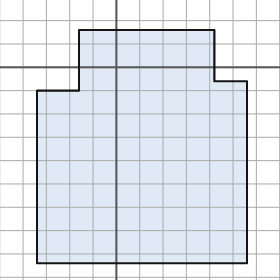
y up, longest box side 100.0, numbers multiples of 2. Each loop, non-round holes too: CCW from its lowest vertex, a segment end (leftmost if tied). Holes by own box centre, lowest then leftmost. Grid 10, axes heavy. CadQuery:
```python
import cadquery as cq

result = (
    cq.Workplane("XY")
    .moveTo(-34.0, -84.0)
    .lineTo(56.0, -84.0)
    .lineTo(56.0, -6.0)
    .lineTo(42.0, -6.0)
    .lineTo(42.0, 16.0)
    .lineTo(-16.0, 16.0)
    .lineTo(-16.0, -10.0)
    .lineTo(-34.0, -10.0)
    .close()
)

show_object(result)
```